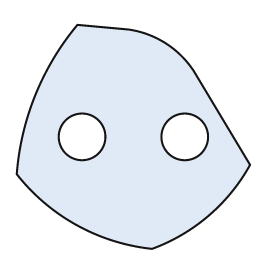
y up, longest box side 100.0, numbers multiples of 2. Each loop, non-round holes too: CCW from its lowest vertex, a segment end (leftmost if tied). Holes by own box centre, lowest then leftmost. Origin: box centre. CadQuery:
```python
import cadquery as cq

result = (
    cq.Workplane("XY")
    .moveTo(8.0, -48.0)
    .threePointArc((32.0, -34.0), (50.0, -12.0))
    .lineTo(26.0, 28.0)
    .threePointArc((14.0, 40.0), (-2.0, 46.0))
    .lineTo(-24.0, 48.0)
    .threePointArc((-42.0, 18.0), (-50.0, -16.0))
    .threePointArc((-24.0, -38.0), (8.0, -48.0))
    .close()
    .moveTo(-22.0, 0.0)
    .circle(10.0)
    .moveTo(22.0, 0.0)
    .circle(10.0)
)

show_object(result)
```